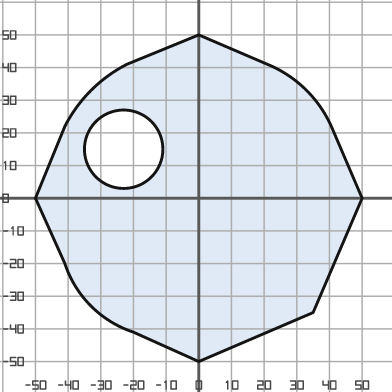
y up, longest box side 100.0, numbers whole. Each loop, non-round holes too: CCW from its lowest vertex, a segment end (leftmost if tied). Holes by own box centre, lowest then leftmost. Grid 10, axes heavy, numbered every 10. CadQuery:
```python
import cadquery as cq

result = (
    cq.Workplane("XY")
    .moveTo(0.0, -50.0)
    .lineTo(35.0, -35.0)
    .lineTo(50.0, 0.0)
    .lineTo(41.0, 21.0)
    .threePointArc((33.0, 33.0), (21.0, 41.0))
    .lineTo(0.0, 50.0)
    .lineTo(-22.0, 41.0)
    .threePointArc((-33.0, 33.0), (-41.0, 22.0))
    .lineTo(-50.0, 0.0)
    .lineTo(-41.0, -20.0)
    .threePointArc((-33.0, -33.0), (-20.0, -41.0))
    .close()
    .moveTo(-23.0, 15.0)
    .circle(12.0)
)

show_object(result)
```